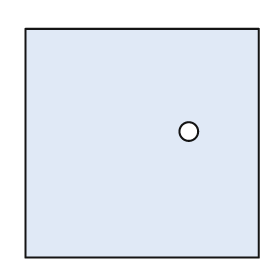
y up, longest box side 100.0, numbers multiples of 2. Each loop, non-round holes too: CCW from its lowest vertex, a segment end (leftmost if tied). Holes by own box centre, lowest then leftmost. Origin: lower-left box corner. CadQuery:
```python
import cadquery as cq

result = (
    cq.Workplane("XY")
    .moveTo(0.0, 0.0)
    .lineTo(100.0, 0.0)
    .lineTo(100.0, 98.0)
    .lineTo(0.0, 98.0)
    .close()
    .moveTo(70.0, 54.0)
    .circle(4.0)
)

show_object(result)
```